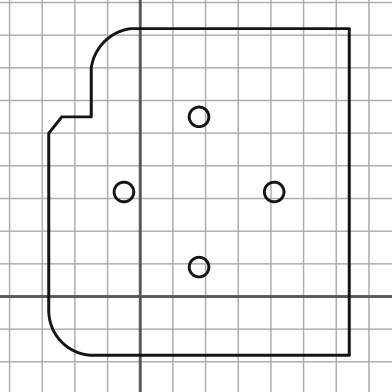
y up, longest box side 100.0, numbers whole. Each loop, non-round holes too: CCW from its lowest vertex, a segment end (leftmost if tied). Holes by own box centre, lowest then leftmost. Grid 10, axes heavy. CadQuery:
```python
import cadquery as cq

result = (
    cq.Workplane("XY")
    .moveTo(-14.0, -18.0)
    .lineTo(64.0, -18.0)
    .lineTo(64.0, 82.0)
    .lineTo(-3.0, 82.0)
    .threePointArc((-11.0, 78.0), (-15.0, 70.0))
    .lineTo(-15.0, 55.0)
    .lineTo(-24.0, 55.0)
    .lineTo(-28.0, 50.0)
    .lineTo(-28.0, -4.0)
    .threePointArc((-24.0, -14.0), (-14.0, -18.0))
    .close()
    .moveTo(18.0, 9.0)
    .circle(3.0)
    .moveTo(-5.0, 32.0)
    .circle(3.0)
    .moveTo(41.0, 32.0)
    .circle(3.0)
    .moveTo(18.0, 55.0)
    .circle(3.0)
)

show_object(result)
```